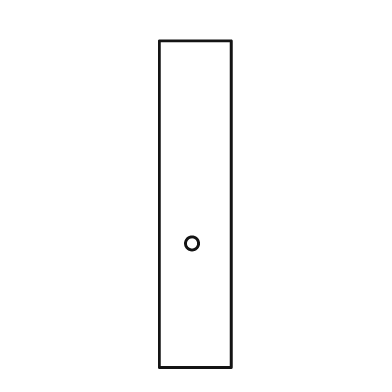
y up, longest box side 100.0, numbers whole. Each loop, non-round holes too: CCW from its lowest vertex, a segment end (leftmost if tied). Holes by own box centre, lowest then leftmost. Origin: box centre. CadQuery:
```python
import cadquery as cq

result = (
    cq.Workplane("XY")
    .moveTo(-11.0, -50.0)
    .lineTo(11.0, -50.0)
    .lineTo(11.0, 50.0)
    .lineTo(-11.0, 50.0)
    .close()
    .moveTo(-1.0, -12.0)
    .circle(2.0)
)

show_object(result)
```